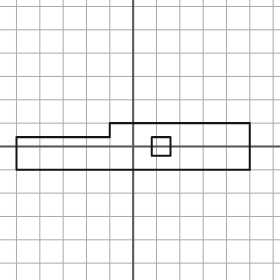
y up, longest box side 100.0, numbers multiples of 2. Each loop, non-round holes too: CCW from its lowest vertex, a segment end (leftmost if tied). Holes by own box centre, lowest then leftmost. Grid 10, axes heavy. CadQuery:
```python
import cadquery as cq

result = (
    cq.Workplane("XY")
    .moveTo(-50.0, -10.0)
    .lineTo(50.0, -10.0)
    .lineTo(50.0, 10.0)
    .lineTo(-10.0, 10.0)
    .lineTo(-10.0, 4.0)
    .lineTo(-50.0, 4.0)
    .close()
    .moveTo(8.0, -4.0)
    .lineTo(16.0, -4.0)
    .lineTo(16.0, 4.0)
    .lineTo(8.0, 4.0)
    .close()
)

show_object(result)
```